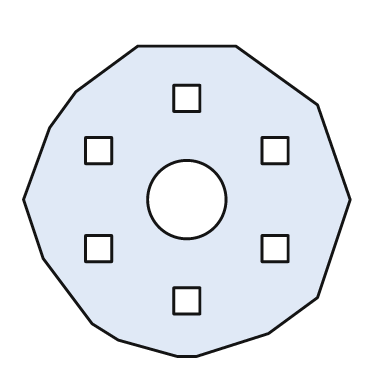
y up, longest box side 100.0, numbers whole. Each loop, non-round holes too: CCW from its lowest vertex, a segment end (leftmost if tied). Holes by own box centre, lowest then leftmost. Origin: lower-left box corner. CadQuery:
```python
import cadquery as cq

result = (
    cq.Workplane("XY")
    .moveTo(47.0, 0.0)
    .lineTo(53.0, 0.0)
    .lineTo(75.0, 7.0)
    .lineTo(90.0, 18.0)
    .lineTo(100.0, 48.0)
    .lineTo(90.0, 77.0)
    .lineTo(65.0, 95.0)
    .lineTo(35.0, 95.0)
    .lineTo(16.0, 81.0)
    .lineTo(8.0, 70.0)
    .lineTo(0.0, 48.0)
    .lineTo(6.0, 30.0)
    .lineTo(21.0, 10.0)
    .lineTo(29.0, 5.0)
    .close()
    .moveTo(46.0, 13.0)
    .lineTo(54.0, 13.0)
    .lineTo(54.0, 21.0)
    .lineTo(46.0, 21.0)
    .close()
    .moveTo(19.0, 29.0)
    .lineTo(27.0, 29.0)
    .lineTo(27.0, 37.0)
    .lineTo(19.0, 37.0)
    .close()
    .moveTo(73.0, 29.0)
    .lineTo(81.0, 29.0)
    .lineTo(81.0, 37.0)
    .lineTo(73.0, 37.0)
    .close()
    .moveTo(50.0, 48.0)
    .circle(12.0)
    .moveTo(19.0, 59.0)
    .lineTo(27.0, 59.0)
    .lineTo(27.0, 67.0)
    .lineTo(19.0, 67.0)
    .close()
    .moveTo(73.0, 59.0)
    .lineTo(81.0, 59.0)
    .lineTo(81.0, 67.0)
    .lineTo(73.0, 67.0)
    .close()
    .moveTo(46.0, 75.0)
    .lineTo(54.0, 75.0)
    .lineTo(54.0, 83.0)
    .lineTo(46.0, 83.0)
    .close()
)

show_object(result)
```